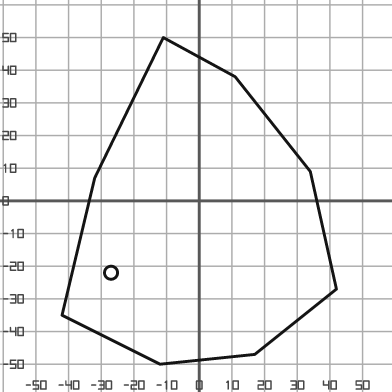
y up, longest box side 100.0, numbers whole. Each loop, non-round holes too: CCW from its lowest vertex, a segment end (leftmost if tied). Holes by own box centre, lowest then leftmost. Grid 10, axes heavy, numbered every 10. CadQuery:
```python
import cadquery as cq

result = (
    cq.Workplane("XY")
    .moveTo(-12.0, -50.0)
    .lineTo(17.0, -47.0)
    .lineTo(42.0, -27.0)
    .lineTo(34.0, 9.0)
    .lineTo(11.0, 38.0)
    .lineTo(-11.0, 50.0)
    .lineTo(-32.0, 7.0)
    .lineTo(-42.0, -35.0)
    .close()
    .moveTo(-27.0, -22.0)
    .circle(2.0)
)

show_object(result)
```